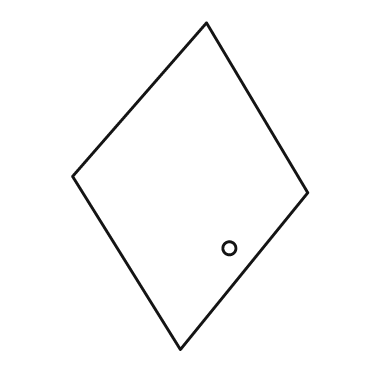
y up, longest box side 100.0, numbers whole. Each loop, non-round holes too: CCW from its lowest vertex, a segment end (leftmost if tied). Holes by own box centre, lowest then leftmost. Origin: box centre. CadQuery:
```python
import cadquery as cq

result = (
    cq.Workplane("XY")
    .moveTo(-3.0, -50.0)
    .lineTo(36.0, -2.0)
    .lineTo(5.0, 50.0)
    .lineTo(-36.0, 3.0)
    .close()
    .moveTo(12.0, -19.0)
    .circle(2.0)
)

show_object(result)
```